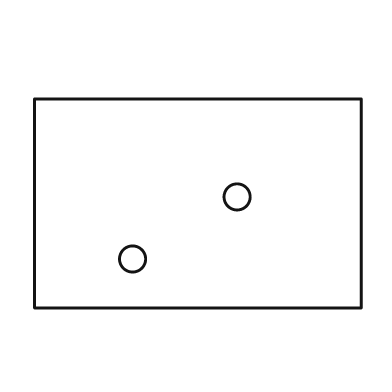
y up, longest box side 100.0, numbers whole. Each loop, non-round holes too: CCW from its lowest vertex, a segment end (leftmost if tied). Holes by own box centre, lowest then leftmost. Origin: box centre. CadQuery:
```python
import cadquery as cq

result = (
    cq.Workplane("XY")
    .moveTo(-50.0, -32.0)
    .lineTo(50.0, -32.0)
    .lineTo(50.0, 32.0)
    .lineTo(-50.0, 32.0)
    .close()
    .moveTo(-20.0, -17.0)
    .circle(4.0)
    .moveTo(12.0, 2.0)
    .circle(4.0)
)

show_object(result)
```